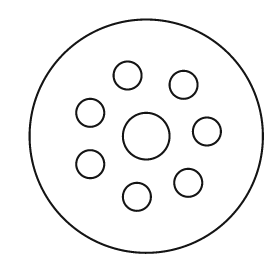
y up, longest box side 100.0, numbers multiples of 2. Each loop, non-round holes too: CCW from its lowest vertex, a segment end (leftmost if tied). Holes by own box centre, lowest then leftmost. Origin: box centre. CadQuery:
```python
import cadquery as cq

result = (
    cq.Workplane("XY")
    .moveTo(0.0, 0.0)
    .circle(50.0)
    .moveTo(-4.0, -26.0)
    .circle(6.0)
    .moveTo(18.0, -20.0)
    .circle(6.0)
    .moveTo(-24.0, -12.0)
    .circle(6.0)
    .moveTo(0.0, 0.0)
    .circle(10.0)
    .moveTo(26.0, 2.0)
    .circle(6.0)
    .moveTo(-24.0, 10.0)
    .circle(6.0)
    .moveTo(16.0, 22.0)
    .circle(6.0)
    .moveTo(-8.0, 26.0)
    .circle(6.0)
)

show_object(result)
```